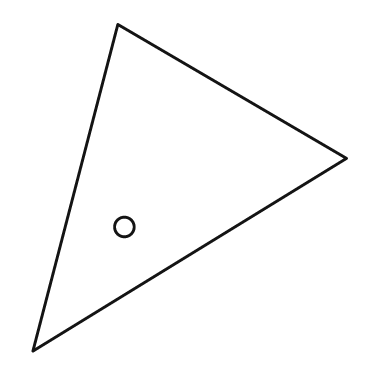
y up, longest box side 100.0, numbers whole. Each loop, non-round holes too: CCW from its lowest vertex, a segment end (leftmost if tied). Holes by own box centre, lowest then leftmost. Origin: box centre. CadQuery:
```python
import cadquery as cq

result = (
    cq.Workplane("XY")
    .moveTo(-48.0, -50.0)
    .lineTo(48.0, 9.0)
    .lineTo(-22.0, 50.0)
    .close()
    .moveTo(-20.0, -12.0)
    .circle(3.0)
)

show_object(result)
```